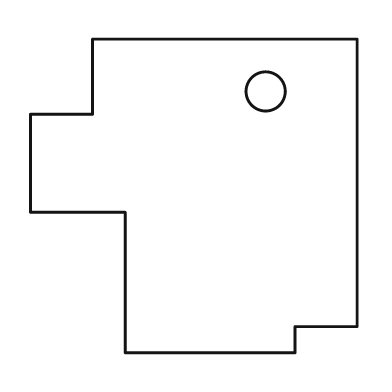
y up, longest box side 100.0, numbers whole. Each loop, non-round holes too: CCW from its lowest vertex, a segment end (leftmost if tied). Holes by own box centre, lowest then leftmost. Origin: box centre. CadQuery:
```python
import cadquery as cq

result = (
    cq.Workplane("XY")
    .moveTo(-21.0, -48.0)
    .lineTo(31.0, -48.0)
    .lineTo(31.0, -40.0)
    .lineTo(50.0, -40.0)
    .lineTo(50.0, 48.0)
    .lineTo(-31.0, 48.0)
    .lineTo(-31.0, 25.0)
    .lineTo(-50.0, 25.0)
    .lineTo(-50.0, -5.0)
    .lineTo(-21.0, -5.0)
    .close()
    .moveTo(22.0, 32.0)
    .circle(6.0)
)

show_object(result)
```